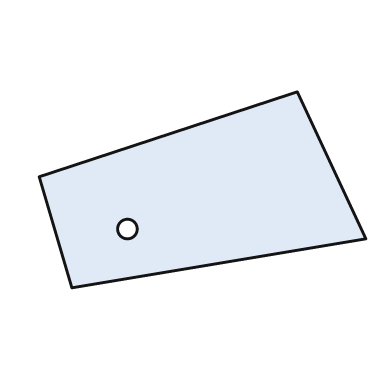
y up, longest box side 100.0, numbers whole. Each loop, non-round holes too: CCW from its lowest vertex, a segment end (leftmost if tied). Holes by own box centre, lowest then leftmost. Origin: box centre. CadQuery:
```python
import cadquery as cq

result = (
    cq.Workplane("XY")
    .moveTo(-40.0, -30.0)
    .lineTo(50.0, -15.0)
    .lineTo(29.0, 30.0)
    .lineTo(-50.0, 4.0)
    .close()
    .moveTo(-23.0, -12.0)
    .circle(3.0)
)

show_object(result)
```